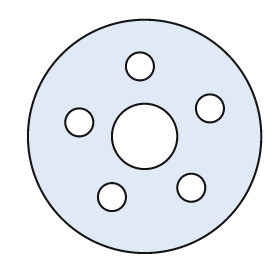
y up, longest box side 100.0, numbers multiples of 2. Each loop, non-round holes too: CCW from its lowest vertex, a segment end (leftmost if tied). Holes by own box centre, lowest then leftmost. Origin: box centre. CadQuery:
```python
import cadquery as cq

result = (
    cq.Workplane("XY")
    .moveTo(0.0, 0.0)
    .circle(50.0)
    .moveTo(-14.0, -26.0)
    .circle(6.0)
    .moveTo(20.0, -22.0)
    .circle(6.0)
    .moveTo(0.0, 0.0)
    .circle(14.0)
    .moveTo(-28.0, 6.0)
    .circle(6.0)
    .moveTo(28.0, 12.0)
    .circle(6.0)
    .moveTo(-2.0, 30.0)
    .circle(6.0)
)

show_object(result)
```